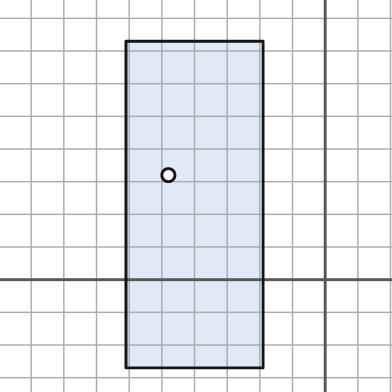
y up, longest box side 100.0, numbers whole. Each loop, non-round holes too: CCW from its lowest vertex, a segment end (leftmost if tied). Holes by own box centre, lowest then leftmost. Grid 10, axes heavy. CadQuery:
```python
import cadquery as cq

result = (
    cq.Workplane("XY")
    .moveTo(-61.0, -27.0)
    .lineTo(-19.0, -27.0)
    .lineTo(-19.0, 73.0)
    .lineTo(-61.0, 73.0)
    .close()
    .moveTo(-48.0, 32.0)
    .circle(2.0)
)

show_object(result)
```